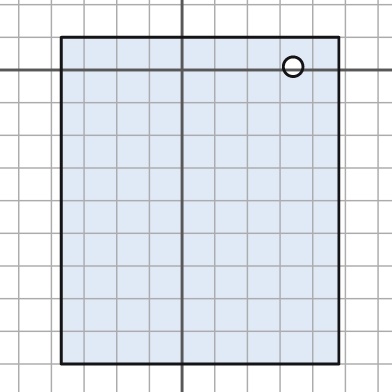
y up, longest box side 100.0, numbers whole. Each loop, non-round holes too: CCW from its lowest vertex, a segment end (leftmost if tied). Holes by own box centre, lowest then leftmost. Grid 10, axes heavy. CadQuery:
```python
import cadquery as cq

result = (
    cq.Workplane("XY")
    .moveTo(-37.0, -90.0)
    .lineTo(48.0, -90.0)
    .lineTo(48.0, 10.0)
    .lineTo(-37.0, 10.0)
    .close()
    .moveTo(34.0, 1.0)
    .circle(3.0)
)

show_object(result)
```